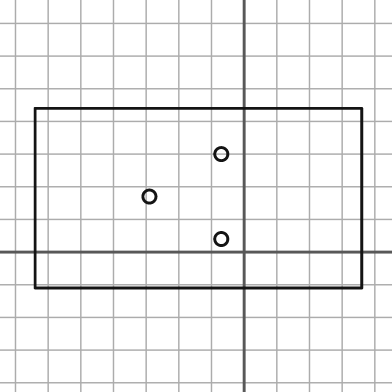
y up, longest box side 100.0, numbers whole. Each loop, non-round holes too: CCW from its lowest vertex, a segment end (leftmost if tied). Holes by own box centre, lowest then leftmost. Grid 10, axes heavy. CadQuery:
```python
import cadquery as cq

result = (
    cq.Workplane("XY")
    .moveTo(-64.0, -11.0)
    .lineTo(36.0, -11.0)
    .lineTo(36.0, 44.0)
    .lineTo(-64.0, 44.0)
    .close()
    .moveTo(-7.0, 4.0)
    .circle(2.0)
    .moveTo(-29.0, 17.0)
    .circle(2.0)
    .moveTo(-7.0, 30.0)
    .circle(2.0)
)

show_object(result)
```